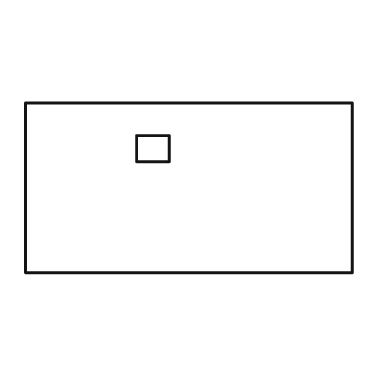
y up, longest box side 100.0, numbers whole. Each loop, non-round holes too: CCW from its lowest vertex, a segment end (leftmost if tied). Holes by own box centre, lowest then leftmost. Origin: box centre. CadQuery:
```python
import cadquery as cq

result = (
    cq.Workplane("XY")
    .moveTo(-50.0, -26.0)
    .lineTo(50.0, -26.0)
    .lineTo(50.0, 26.0)
    .lineTo(-50.0, 26.0)
    .close()
    .moveTo(-16.0, 8.0)
    .lineTo(-6.0, 8.0)
    .lineTo(-6.0, 16.0)
    .lineTo(-16.0, 16.0)
    .close()
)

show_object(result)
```